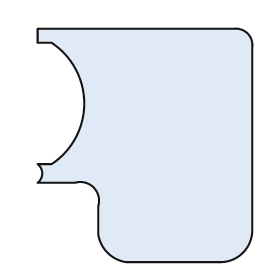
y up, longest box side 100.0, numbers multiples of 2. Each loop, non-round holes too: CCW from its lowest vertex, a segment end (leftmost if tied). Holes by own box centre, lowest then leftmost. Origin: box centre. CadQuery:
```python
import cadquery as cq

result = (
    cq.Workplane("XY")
    .moveTo(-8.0, -50.0)
    .lineTo(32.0, -50.0)
    .threePointArc((42.0, -46.0), (46.0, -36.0))
    .lineTo(46.0, 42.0)
    .threePointArc((44.0, 48.0), (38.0, 50.0))
    .lineTo(-46.0, 50.0)
    .lineTo(-46.0, 44.0)
    .lineTo(-40.0, 44.0)
    .threePointArc((-26.0, 18.0), (-40.0, -8.0))
    .lineTo(-46.0, -8.0)
    .threePointArc((-44.0, -12.0), (-46.0, -16.0))
    .lineTo(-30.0, -16.0)
    .threePointArc((-22.0, -18.0), (-20.0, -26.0))
    .lineTo(-20.0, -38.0)
    .threePointArc((-16.0, -46.0), (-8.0, -50.0))
    .close()
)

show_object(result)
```